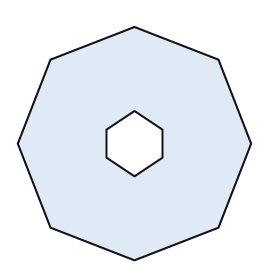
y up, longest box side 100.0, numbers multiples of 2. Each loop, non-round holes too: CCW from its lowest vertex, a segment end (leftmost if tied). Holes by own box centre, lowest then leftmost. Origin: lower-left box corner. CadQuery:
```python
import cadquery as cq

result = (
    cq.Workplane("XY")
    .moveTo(50.0, 0.0)
    .lineTo(86.0, 14.0)
    .lineTo(100.0, 50.0)
    .lineTo(86.0, 86.0)
    .lineTo(50.0, 100.0)
    .lineTo(14.0, 86.0)
    .lineTo(0.0, 50.0)
    .lineTo(14.0, 14.0)
    .close()
    .moveTo(50.0, 36.0)
    .lineTo(62.0, 44.0)
    .lineTo(62.0, 56.0)
    .lineTo(50.0, 64.0)
    .lineTo(38.0, 56.0)
    .lineTo(38.0, 44.0)
    .close()
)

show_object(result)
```